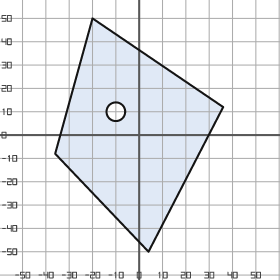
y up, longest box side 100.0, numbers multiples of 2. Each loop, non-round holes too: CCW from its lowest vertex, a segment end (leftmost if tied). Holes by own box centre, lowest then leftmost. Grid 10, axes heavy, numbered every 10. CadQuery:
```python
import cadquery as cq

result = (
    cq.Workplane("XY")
    .moveTo(4.0, -50.0)
    .lineTo(36.0, 12.0)
    .lineTo(-20.0, 50.0)
    .lineTo(-36.0, -8.0)
    .close()
    .moveTo(-10.0, 10.0)
    .circle(4.0)
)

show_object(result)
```